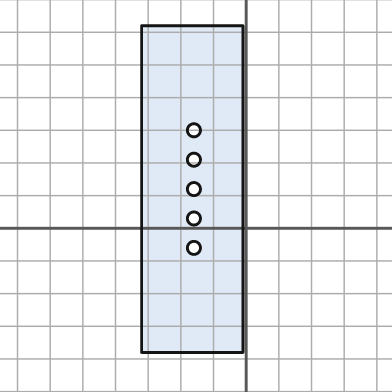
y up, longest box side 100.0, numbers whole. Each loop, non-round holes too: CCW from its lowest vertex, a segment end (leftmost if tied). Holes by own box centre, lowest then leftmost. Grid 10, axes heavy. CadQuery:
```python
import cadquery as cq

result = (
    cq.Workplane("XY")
    .moveTo(-32.0, -38.0)
    .lineTo(-1.0, -38.0)
    .lineTo(-1.0, 62.0)
    .lineTo(-32.0, 62.0)
    .close()
    .moveTo(-16.0, -6.0)
    .circle(2.0)
    .moveTo(-16.0, 3.0)
    .circle(2.0)
    .moveTo(-16.0, 12.0)
    .circle(2.0)
    .moveTo(-16.0, 21.0)
    .circle(2.0)
    .moveTo(-16.0, 30.0)
    .circle(2.0)
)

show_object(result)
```